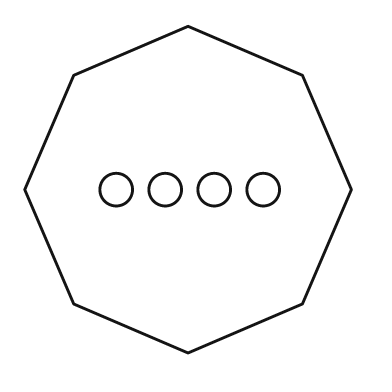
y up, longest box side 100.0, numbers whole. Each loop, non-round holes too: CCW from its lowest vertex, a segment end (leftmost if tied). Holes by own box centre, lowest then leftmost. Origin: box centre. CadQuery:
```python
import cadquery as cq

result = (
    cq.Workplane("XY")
    .moveTo(0.0, -50.0)
    .lineTo(35.0, -35.0)
    .lineTo(50.0, 0.0)
    .lineTo(35.0, 35.0)
    .lineTo(0.0, 50.0)
    .lineTo(-35.0, 35.0)
    .lineTo(-50.0, 0.0)
    .lineTo(-35.0, -35.0)
    .close()
    .moveTo(-22.0, 0.0)
    .circle(5.0)
    .moveTo(-7.0, 0.0)
    .circle(5.0)
    .moveTo(8.0, 0.0)
    .circle(5.0)
    .moveTo(23.0, 0.0)
    .circle(5.0)
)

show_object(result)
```